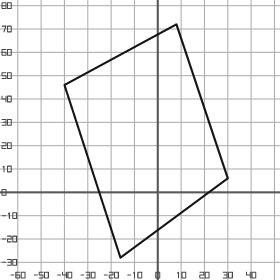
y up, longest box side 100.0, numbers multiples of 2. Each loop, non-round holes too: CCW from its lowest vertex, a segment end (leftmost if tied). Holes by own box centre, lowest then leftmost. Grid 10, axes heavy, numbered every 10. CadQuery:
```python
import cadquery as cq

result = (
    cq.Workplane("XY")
    .moveTo(-16.0, -28.0)
    .lineTo(30.0, 6.0)
    .lineTo(8.0, 72.0)
    .lineTo(-40.0, 46.0)
    .close()
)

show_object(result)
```